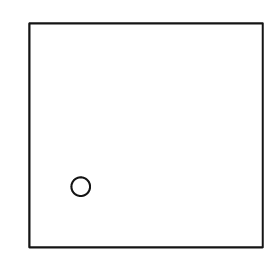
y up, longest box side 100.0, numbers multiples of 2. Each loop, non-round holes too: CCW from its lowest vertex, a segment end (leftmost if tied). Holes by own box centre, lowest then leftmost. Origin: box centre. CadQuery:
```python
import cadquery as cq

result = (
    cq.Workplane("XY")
    .moveTo(-50.0, -48.0)
    .lineTo(50.0, -48.0)
    .lineTo(50.0, 48.0)
    .lineTo(-50.0, 48.0)
    .close()
    .moveTo(-28.0, -22.0)
    .circle(4.0)
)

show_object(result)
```